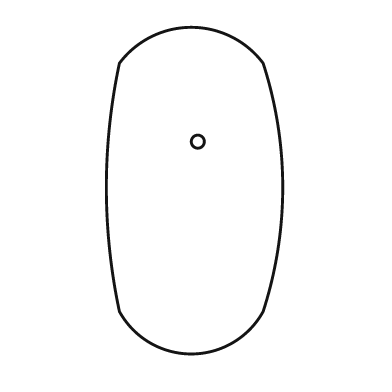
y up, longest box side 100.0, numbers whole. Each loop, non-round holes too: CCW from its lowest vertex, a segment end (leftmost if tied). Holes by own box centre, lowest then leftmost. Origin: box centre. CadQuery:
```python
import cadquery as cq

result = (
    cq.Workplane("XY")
    .moveTo(-23.0, -37.0)
    .threePointArc((-1.0, -50.0), (21.0, -37.0))
    .threePointArc((27.0, 1.0), (21.0, 39.0))
    .threePointArc((-1.0, 50.0), (-23.0, 39.0))
    .threePointArc((-27.0, 1.0), (-23.0, -37.0))
    .close()
    .moveTo(1.0, 15.0)
    .circle(2.0)
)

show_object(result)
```